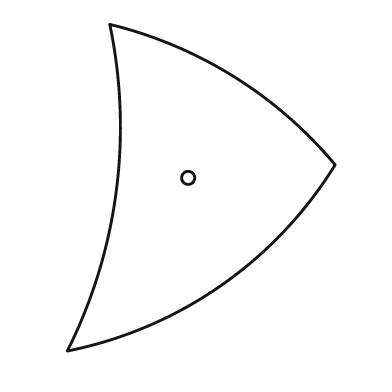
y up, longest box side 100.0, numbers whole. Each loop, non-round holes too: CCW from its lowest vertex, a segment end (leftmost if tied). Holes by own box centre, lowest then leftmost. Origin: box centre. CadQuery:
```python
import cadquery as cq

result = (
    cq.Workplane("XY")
    .moveTo(-41.0, -50.0)
    .threePointArc((6.0, -30.0), (41.0, 7.0))
    .threePointArc((10.0, 34.0), (-28.0, 50.0))
    .threePointArc((-26.0, -1.0), (-41.0, -50.0))
    .close()
    .moveTo(-4.0, 3.0)
    .circle(2.0)
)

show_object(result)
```